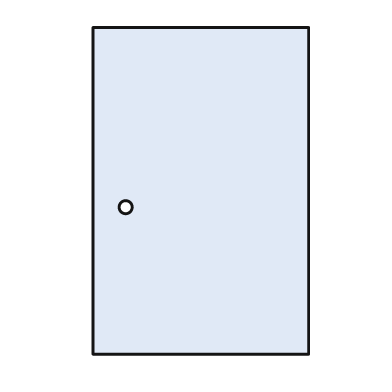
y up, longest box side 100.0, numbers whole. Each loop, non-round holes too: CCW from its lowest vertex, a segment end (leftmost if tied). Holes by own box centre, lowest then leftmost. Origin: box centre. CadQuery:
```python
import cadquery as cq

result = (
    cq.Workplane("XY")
    .moveTo(-33.0, -50.0)
    .lineTo(33.0, -50.0)
    .lineTo(33.0, 50.0)
    .lineTo(-33.0, 50.0)
    .close()
    .moveTo(-23.0, -5.0)
    .circle(2.0)
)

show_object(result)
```